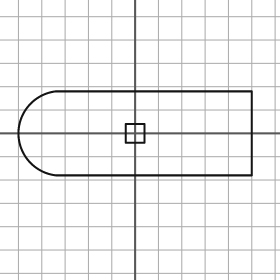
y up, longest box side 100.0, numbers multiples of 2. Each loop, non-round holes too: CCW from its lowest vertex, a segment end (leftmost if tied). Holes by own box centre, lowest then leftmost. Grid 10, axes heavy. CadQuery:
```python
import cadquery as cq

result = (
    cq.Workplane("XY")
    .moveTo(-34.0, -18.0)
    .lineTo(50.0, -18.0)
    .lineTo(50.0, 18.0)
    .lineTo(-34.0, 18.0)
    .threePointArc((-50.0, 0.0), (-34.0, -18.0))
    .close()
    .moveTo(-4.0, -4.0)
    .lineTo(4.0, -4.0)
    .lineTo(4.0, 4.0)
    .lineTo(-4.0, 4.0)
    .close()
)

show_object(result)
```